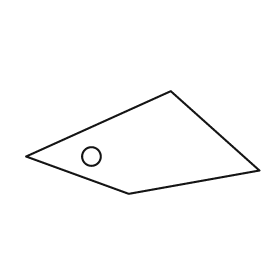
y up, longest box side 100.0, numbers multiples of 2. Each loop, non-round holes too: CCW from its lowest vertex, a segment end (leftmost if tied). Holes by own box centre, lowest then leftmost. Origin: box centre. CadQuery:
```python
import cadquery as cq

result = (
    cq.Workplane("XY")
    .moveTo(-6.0, -22.0)
    .lineTo(50.0, -12.0)
    .lineTo(12.0, 22.0)
    .lineTo(-50.0, -6.0)
    .close()
    .moveTo(-22.0, -6.0)
    .circle(4.0)
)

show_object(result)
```